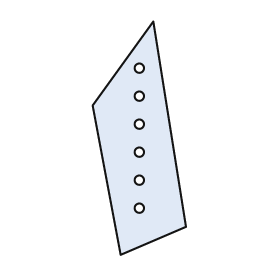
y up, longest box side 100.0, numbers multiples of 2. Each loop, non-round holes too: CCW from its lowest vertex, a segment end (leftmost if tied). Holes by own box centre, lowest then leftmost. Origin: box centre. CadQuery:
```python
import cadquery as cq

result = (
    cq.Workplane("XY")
    .moveTo(-8.0, -50.0)
    .lineTo(20.0, -38.0)
    .lineTo(6.0, 50.0)
    .lineTo(-20.0, 14.0)
    .close()
    .moveTo(0.0, -30.0)
    .circle(2.0)
    .moveTo(0.0, -18.0)
    .circle(2.0)
    .moveTo(0.0, -6.0)
    .circle(2.0)
    .moveTo(0.0, 6.0)
    .circle(2.0)
    .moveTo(0.0, 18.0)
    .circle(2.0)
    .moveTo(0.0, 30.0)
    .circle(2.0)
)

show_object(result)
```